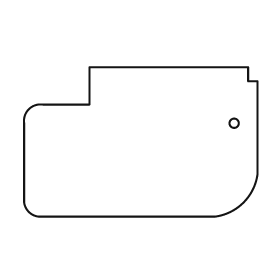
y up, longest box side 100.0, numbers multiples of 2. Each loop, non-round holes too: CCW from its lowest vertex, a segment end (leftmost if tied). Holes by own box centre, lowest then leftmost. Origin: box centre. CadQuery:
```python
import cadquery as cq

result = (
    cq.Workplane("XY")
    .moveTo(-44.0, -32.0)
    .lineTo(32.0, -32.0)
    .threePointArc((44.0, -26.0), (50.0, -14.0))
    .lineTo(50.0, 26.0)
    .lineTo(46.0, 26.0)
    .lineTo(46.0, 32.0)
    .lineTo(-22.0, 32.0)
    .lineTo(-22.0, 16.0)
    .lineTo(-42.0, 16.0)
    .threePointArc((-48.0, 14.0), (-50.0, 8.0))
    .lineTo(-50.0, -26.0)
    .threePointArc((-48.0, -30.0), (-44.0, -32.0))
    .close()
    .moveTo(40.0, 8.0)
    .circle(2.0)
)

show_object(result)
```